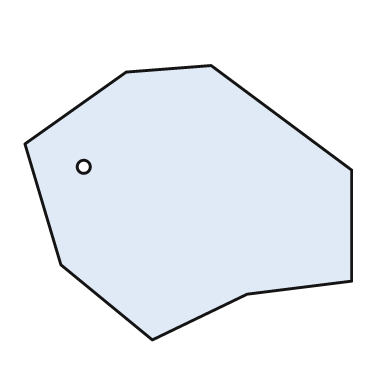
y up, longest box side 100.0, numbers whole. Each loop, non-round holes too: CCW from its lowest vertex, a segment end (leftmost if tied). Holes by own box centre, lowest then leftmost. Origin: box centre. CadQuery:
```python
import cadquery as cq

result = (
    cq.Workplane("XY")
    .moveTo(-11.0, -42.0)
    .lineTo(18.0, -28.0)
    .lineTo(50.0, -24.0)
    .lineTo(50.0, 10.0)
    .lineTo(7.0, 42.0)
    .lineTo(-19.0, 40.0)
    .lineTo(-50.0, 18.0)
    .lineTo(-39.0, -19.0)
    .close()
    .moveTo(-32.0, 11.0)
    .circle(2.0)
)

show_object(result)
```